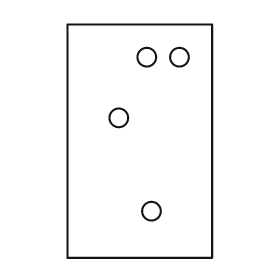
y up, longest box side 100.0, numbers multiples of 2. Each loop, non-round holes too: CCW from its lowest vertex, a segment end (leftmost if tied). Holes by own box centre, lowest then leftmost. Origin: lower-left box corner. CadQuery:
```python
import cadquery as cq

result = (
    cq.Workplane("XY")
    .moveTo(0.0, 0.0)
    .lineTo(62.0, 0.0)
    .lineTo(62.0, 100.0)
    .lineTo(0.0, 100.0)
    .close()
    .moveTo(36.0, 20.0)
    .circle(4.0)
    .moveTo(22.0, 60.0)
    .circle(4.0)
    .moveTo(34.0, 86.0)
    .circle(4.0)
    .moveTo(48.0, 86.0)
    .circle(4.0)
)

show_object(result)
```